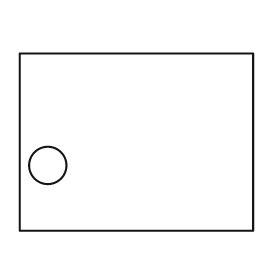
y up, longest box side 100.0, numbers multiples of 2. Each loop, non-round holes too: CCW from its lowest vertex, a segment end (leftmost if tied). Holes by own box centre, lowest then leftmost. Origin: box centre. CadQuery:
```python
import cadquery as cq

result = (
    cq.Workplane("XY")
    .moveTo(-50.0, -38.0)
    .lineTo(50.0, -38.0)
    .lineTo(50.0, 38.0)
    .lineTo(-50.0, 38.0)
    .close()
    .moveTo(-38.0, -10.0)
    .circle(8.0)
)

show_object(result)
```